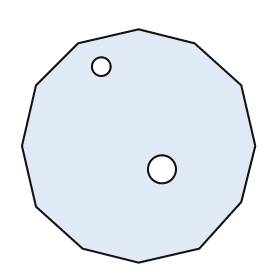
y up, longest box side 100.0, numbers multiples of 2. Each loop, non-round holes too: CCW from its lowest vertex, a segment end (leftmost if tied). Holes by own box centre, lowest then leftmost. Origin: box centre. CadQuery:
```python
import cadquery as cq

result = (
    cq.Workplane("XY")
    .moveTo(0.0, -50.0)
    .lineTo(26.0, -44.0)
    .lineTo(44.0, -24.0)
    .lineTo(50.0, 0.0)
    .lineTo(44.0, 26.0)
    .lineTo(24.0, 44.0)
    .lineTo(0.0, 50.0)
    .lineTo(-26.0, 44.0)
    .lineTo(-44.0, 26.0)
    .lineTo(-50.0, 0.0)
    .lineTo(-44.0, -26.0)
    .lineTo(-24.0, -44.0)
    .close()
    .moveTo(10.0, -10.0)
    .circle(6.0)
    .moveTo(-16.0, 34.0)
    .circle(4.0)
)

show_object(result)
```